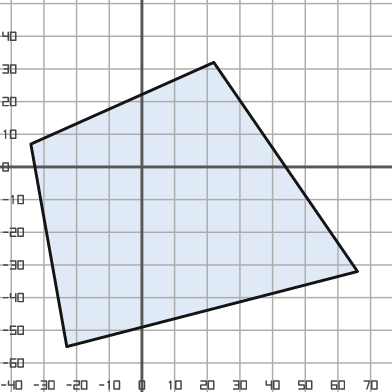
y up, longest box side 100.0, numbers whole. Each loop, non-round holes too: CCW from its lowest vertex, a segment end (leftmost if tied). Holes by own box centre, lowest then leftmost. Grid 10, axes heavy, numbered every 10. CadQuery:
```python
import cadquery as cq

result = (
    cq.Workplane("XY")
    .moveTo(-23.0, -55.0)
    .lineTo(66.0, -32.0)
    .lineTo(22.0, 32.0)
    .lineTo(-34.0, 7.0)
    .close()
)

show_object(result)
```